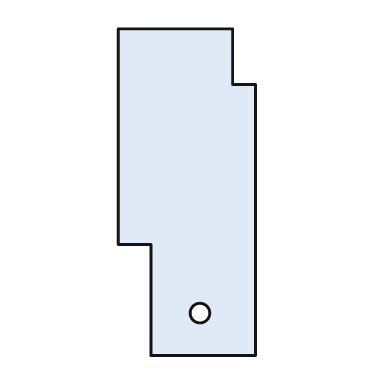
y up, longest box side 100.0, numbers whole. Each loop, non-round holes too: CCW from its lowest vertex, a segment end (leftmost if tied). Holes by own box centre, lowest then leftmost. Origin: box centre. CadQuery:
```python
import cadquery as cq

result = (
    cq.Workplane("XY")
    .moveTo(-11.0, -50.0)
    .lineTo(21.0, -50.0)
    .lineTo(21.0, 33.0)
    .lineTo(14.0, 33.0)
    .lineTo(14.0, 50.0)
    .lineTo(-21.0, 50.0)
    .lineTo(-21.0, -16.0)
    .lineTo(-11.0, -16.0)
    .close()
    .moveTo(4.0, -37.0)
    .circle(3.0)
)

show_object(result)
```